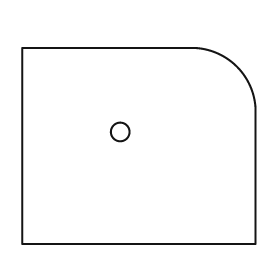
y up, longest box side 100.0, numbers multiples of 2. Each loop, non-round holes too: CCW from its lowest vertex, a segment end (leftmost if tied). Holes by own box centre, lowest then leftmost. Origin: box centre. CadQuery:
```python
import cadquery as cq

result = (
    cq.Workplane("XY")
    .moveTo(-50.0, -42.0)
    .lineTo(50.0, -42.0)
    .lineTo(50.0, 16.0)
    .threePointArc((42.0, 34.0), (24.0, 42.0))
    .lineTo(-50.0, 42.0)
    .close()
    .moveTo(-8.0, 6.0)
    .circle(4.0)
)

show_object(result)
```